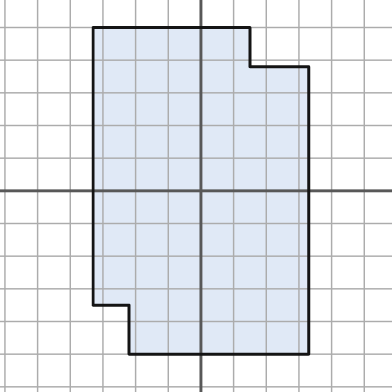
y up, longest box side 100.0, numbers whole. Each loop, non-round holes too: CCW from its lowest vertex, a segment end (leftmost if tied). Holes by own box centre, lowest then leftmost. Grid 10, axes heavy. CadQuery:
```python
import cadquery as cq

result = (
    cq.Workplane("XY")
    .moveTo(-22.0, -50.0)
    .lineTo(33.0, -50.0)
    .lineTo(33.0, 38.0)
    .lineTo(15.0, 38.0)
    .lineTo(15.0, 50.0)
    .lineTo(-33.0, 50.0)
    .lineTo(-33.0, -35.0)
    .lineTo(-22.0, -35.0)
    .close()
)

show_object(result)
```